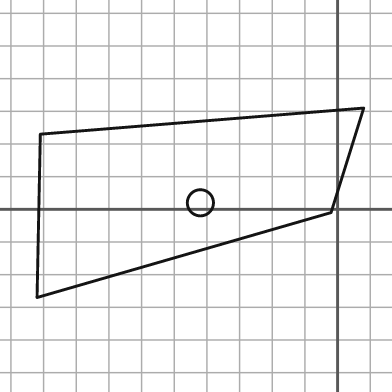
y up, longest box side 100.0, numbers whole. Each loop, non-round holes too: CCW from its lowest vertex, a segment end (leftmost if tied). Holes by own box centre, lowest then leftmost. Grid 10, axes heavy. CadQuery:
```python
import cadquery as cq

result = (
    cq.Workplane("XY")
    .moveTo(-92.0, -27.0)
    .lineTo(-2.0, -1.0)
    .lineTo(8.0, 31.0)
    .lineTo(-91.0, 23.0)
    .close()
    .moveTo(-42.0, 2.0)
    .circle(4.0)
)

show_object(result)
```